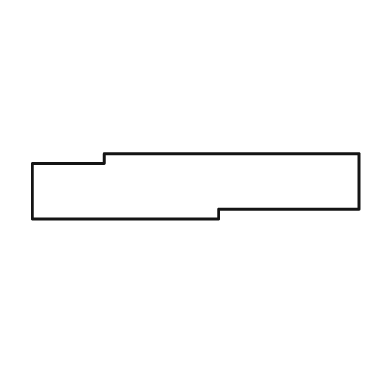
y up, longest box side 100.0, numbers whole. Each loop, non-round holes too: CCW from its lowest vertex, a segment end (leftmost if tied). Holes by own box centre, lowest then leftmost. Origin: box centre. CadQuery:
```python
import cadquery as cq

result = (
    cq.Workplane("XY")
    .moveTo(-50.0, -10.0)
    .lineTo(7.0, -10.0)
    .lineTo(7.0, -7.0)
    .lineTo(50.0, -7.0)
    .lineTo(50.0, 10.0)
    .lineTo(-28.0, 10.0)
    .lineTo(-28.0, 7.0)
    .lineTo(-50.0, 7.0)
    .close()
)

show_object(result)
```